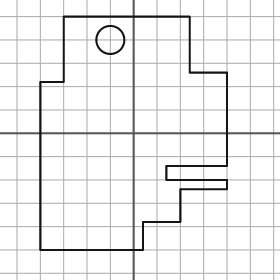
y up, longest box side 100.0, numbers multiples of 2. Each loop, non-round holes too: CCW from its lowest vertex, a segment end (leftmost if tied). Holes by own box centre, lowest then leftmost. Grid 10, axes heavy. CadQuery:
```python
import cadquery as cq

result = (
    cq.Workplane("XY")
    .moveTo(-40.0, -50.0)
    .lineTo(4.0, -50.0)
    .lineTo(4.0, -38.0)
    .lineTo(20.0, -38.0)
    .lineTo(20.0, -24.0)
    .lineTo(40.0, -24.0)
    .lineTo(40.0, -20.0)
    .lineTo(14.0, -20.0)
    .lineTo(14.0, -14.0)
    .lineTo(40.0, -14.0)
    .lineTo(40.0, 26.0)
    .lineTo(24.0, 26.0)
    .lineTo(24.0, 50.0)
    .lineTo(-30.0, 50.0)
    .lineTo(-30.0, 22.0)
    .lineTo(-40.0, 22.0)
    .close()
    .moveTo(-10.0, 40.0)
    .circle(6.0)
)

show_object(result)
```